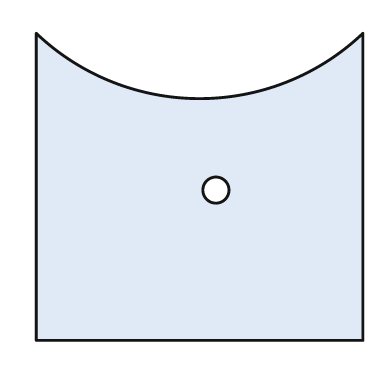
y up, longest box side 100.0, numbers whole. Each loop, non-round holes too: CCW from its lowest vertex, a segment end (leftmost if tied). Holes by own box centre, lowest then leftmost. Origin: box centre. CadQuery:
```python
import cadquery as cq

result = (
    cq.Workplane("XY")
    .moveTo(-50.0, -47.0)
    .lineTo(50.0, -47.0)
    .lineTo(50.0, 47.0)
    .threePointArc((0.0, 27.0), (-50.0, 47.0))
    .close()
    .moveTo(5.0, -1.0)
    .circle(4.0)
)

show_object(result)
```